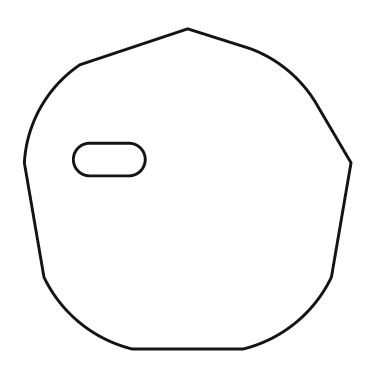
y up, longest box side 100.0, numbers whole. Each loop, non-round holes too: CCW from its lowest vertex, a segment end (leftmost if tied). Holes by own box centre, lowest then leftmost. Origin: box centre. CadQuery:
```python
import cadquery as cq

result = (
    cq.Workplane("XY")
    .moveTo(-17.0, -49.0)
    .lineTo(17.0, -49.0)
    .threePointArc((33.0, -41.0), (44.0, -27.0))
    .lineTo(50.0, 8.0)
    .lineTo(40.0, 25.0)
    .threePointArc((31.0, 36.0), (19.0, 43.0))
    .lineTo(0.0, 49.0)
    .lineTo(-33.0, 38.0)
    .threePointArc((-45.0, 25.0), (-50.0, 8.0))
    .lineTo(-44.0, -27.0)
    .threePointArc((-33.0, -41.0), (-17.0, -49.0))
    .close()
    .moveTo(-30.0, 4.0)
    .lineTo(-18.0, 4.0)
    .threePointArc((-13.0, 9.0), (-18.0, 14.0))
    .lineTo(-30.0, 14.0)
    .threePointArc((-35.0, 9.0), (-30.0, 4.0))
    .close()
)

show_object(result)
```